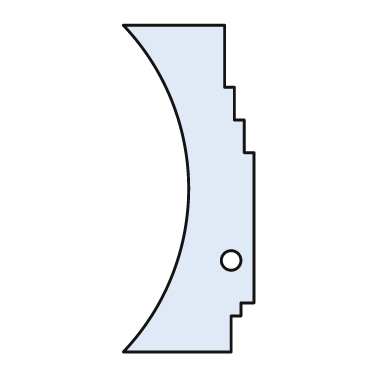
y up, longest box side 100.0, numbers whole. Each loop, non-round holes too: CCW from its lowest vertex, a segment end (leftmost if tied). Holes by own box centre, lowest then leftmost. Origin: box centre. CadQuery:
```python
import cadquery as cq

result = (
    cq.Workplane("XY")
    .moveTo(-20.0, -50.0)
    .lineTo(13.0, -50.0)
    .lineTo(13.0, -39.0)
    .lineTo(16.0, -39.0)
    .lineTo(16.0, -35.0)
    .lineTo(20.0, -35.0)
    .lineTo(20.0, 11.0)
    .lineTo(17.0, 11.0)
    .lineTo(17.0, 21.0)
    .lineTo(14.0, 21.0)
    .lineTo(14.0, 31.0)
    .lineTo(11.0, 31.0)
    .lineTo(11.0, 50.0)
    .lineTo(-20.0, 50.0)
    .threePointArc((0.0, 0.0), (-20.0, -50.0))
    .close()
    .moveTo(13.0, -22.0)
    .circle(3.0)
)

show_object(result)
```